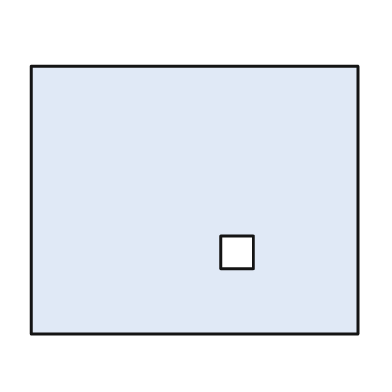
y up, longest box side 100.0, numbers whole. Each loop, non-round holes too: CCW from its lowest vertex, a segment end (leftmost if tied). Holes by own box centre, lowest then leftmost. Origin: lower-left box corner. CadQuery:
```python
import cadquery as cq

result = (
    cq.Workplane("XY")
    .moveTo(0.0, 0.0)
    .lineTo(100.0, 0.0)
    .lineTo(100.0, 82.0)
    .lineTo(0.0, 82.0)
    .close()
    .moveTo(58.0, 20.0)
    .lineTo(68.0, 20.0)
    .lineTo(68.0, 30.0)
    .lineTo(58.0, 30.0)
    .close()
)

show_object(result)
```